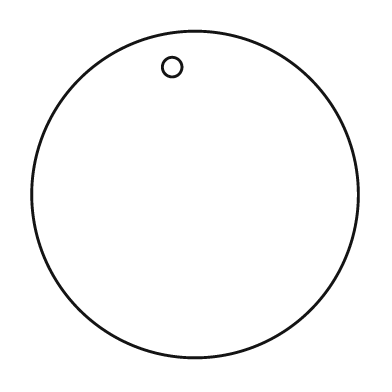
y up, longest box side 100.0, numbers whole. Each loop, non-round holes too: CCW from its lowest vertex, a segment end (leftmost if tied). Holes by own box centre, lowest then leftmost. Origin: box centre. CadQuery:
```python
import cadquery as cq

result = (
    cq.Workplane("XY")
    .moveTo(0.0, 0.0)
    .circle(50.0)
    .moveTo(-7.0, 39.0)
    .circle(3.0)
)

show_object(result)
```